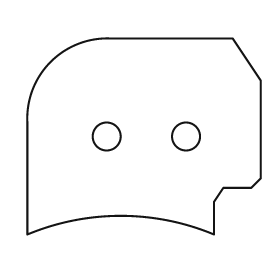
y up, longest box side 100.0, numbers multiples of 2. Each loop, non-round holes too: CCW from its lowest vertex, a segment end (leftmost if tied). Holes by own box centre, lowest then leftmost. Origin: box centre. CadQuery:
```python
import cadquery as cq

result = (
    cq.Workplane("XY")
    .moveTo(-50.0, -42.0)
    .threePointArc((-10.0, -34.0), (30.0, -42.0))
    .lineTo(30.0, -28.0)
    .lineTo(34.0, -22.0)
    .lineTo(46.0, -22.0)
    .lineTo(50.0, -18.0)
    .lineTo(50.0, 24.0)
    .lineTo(38.0, 42.0)
    .lineTo(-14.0, 42.0)
    .threePointArc((-40.0, 32.0), (-50.0, 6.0))
    .close()
    .moveTo(-16.0, 0.0)
    .circle(6.0)
    .moveTo(18.0, 0.0)
    .circle(6.0)
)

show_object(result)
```